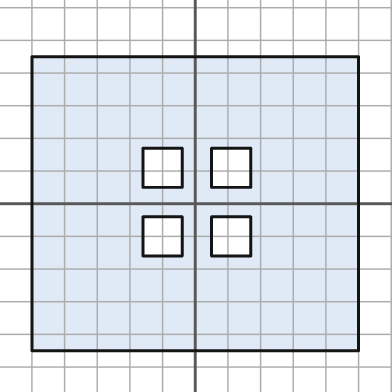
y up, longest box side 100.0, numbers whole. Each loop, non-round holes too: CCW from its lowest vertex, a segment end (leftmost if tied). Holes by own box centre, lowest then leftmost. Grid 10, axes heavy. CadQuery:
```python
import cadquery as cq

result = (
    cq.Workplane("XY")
    .moveTo(-50.0, -45.0)
    .lineTo(50.0, -45.0)
    .lineTo(50.0, 45.0)
    .lineTo(-50.0, 45.0)
    .close()
    .moveTo(-16.0, -16.0)
    .lineTo(-4.0, -16.0)
    .lineTo(-4.0, -4.0)
    .lineTo(-16.0, -4.0)
    .close()
    .moveTo(5.0, -16.0)
    .lineTo(17.0, -16.0)
    .lineTo(17.0, -4.0)
    .lineTo(5.0, -4.0)
    .close()
    .moveTo(-16.0, 5.0)
    .lineTo(-4.0, 5.0)
    .lineTo(-4.0, 17.0)
    .lineTo(-16.0, 17.0)
    .close()
    .moveTo(5.0, 5.0)
    .lineTo(17.0, 5.0)
    .lineTo(17.0, 17.0)
    .lineTo(5.0, 17.0)
    .close()
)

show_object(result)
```